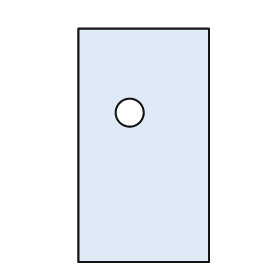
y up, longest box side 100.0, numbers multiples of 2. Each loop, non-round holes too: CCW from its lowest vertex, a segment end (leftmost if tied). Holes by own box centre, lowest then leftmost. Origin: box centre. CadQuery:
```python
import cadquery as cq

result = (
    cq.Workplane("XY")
    .moveTo(-28.0, -50.0)
    .lineTo(28.0, -50.0)
    .lineTo(28.0, 50.0)
    .lineTo(-28.0, 50.0)
    .close()
    .moveTo(-6.0, 14.0)
    .circle(6.0)
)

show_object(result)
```